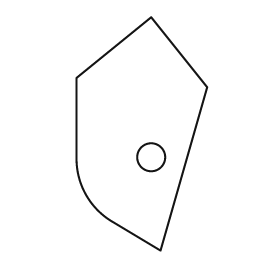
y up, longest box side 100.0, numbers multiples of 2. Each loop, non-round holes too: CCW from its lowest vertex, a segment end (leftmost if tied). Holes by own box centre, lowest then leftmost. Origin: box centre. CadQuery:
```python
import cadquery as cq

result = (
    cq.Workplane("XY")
    .moveTo(8.0, -50.0)
    .lineTo(28.0, 20.0)
    .lineTo(4.0, 50.0)
    .lineTo(-28.0, 24.0)
    .lineTo(-28.0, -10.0)
    .threePointArc((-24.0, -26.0), (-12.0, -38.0))
    .close()
    .moveTo(4.0, -10.0)
    .circle(6.0)
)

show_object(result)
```